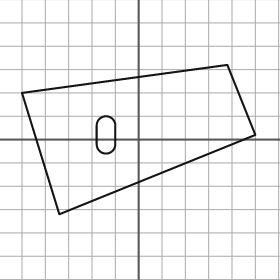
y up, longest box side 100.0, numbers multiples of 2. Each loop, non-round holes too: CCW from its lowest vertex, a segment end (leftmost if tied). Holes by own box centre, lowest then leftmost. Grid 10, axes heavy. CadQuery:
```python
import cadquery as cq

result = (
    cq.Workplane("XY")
    .moveTo(-34.0, -32.0)
    .lineTo(50.0, 2.0)
    .lineTo(38.0, 32.0)
    .lineTo(-50.0, 20.0)
    .close()
    .moveTo(-18.0, -2.0)
    .threePointArc((-14.0, -6.0), (-10.0, -2.0))
    .lineTo(-10.0, 6.0)
    .threePointArc((-14.0, 10.0), (-18.0, 6.0))
    .close()
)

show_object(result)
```